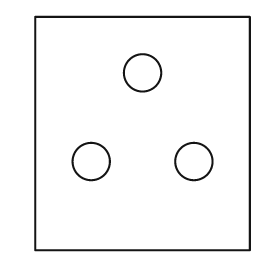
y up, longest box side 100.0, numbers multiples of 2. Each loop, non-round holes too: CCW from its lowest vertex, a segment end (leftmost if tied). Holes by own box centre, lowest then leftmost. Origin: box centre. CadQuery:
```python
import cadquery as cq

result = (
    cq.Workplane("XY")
    .moveTo(-46.0, -50.0)
    .lineTo(46.0, -50.0)
    .lineTo(46.0, 50.0)
    .lineTo(-46.0, 50.0)
    .close()
    .moveTo(-22.0, -12.0)
    .circle(8.0)
    .moveTo(22.0, -12.0)
    .circle(8.0)
    .moveTo(0.0, 26.0)
    .circle(8.0)
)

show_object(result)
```